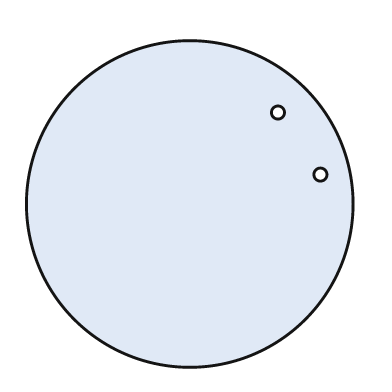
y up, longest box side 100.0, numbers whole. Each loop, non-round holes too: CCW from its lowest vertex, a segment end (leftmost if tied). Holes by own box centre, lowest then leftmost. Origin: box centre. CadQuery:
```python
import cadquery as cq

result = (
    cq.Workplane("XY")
    .moveTo(0.0, 0.0)
    .circle(50.0)
    .moveTo(40.0, 9.0)
    .circle(2.0)
    .moveTo(27.0, 28.0)
    .circle(2.0)
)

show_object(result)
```